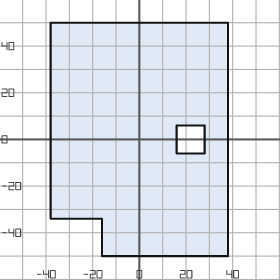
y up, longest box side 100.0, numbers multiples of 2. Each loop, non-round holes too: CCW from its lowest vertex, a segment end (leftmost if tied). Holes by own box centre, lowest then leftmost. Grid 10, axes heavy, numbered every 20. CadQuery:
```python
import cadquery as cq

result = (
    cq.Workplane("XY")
    .moveTo(-16.0, -50.0)
    .lineTo(38.0, -50.0)
    .lineTo(38.0, 50.0)
    .lineTo(-38.0, 50.0)
    .lineTo(-38.0, -34.0)
    .lineTo(-16.0, -34.0)
    .close()
    .moveTo(16.0, -6.0)
    .lineTo(28.0, -6.0)
    .lineTo(28.0, 6.0)
    .lineTo(16.0, 6.0)
    .close()
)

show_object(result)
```